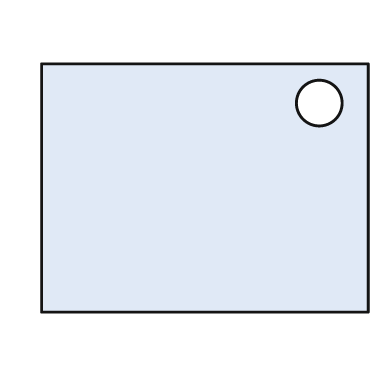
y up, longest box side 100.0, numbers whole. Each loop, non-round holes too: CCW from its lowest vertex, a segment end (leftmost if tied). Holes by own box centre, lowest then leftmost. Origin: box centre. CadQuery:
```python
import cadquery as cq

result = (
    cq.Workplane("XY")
    .moveTo(-50.0, -38.0)
    .lineTo(50.0, -38.0)
    .lineTo(50.0, 38.0)
    .lineTo(-50.0, 38.0)
    .close()
    .moveTo(35.0, 26.0)
    .circle(7.0)
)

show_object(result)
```